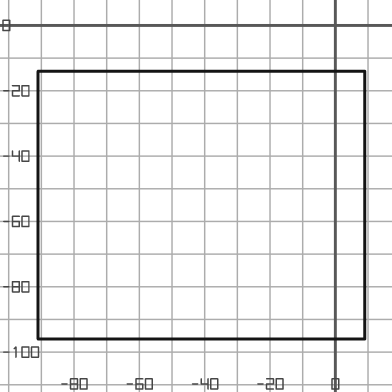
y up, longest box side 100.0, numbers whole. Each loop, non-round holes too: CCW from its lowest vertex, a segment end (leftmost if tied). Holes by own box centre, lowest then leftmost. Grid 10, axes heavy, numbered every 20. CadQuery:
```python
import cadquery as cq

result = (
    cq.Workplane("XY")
    .moveTo(-91.0, -96.0)
    .lineTo(9.0, -96.0)
    .lineTo(9.0, -14.0)
    .lineTo(-91.0, -14.0)
    .close()
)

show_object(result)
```